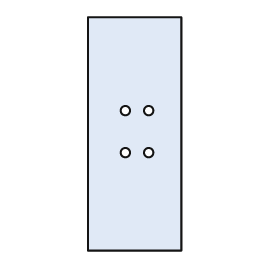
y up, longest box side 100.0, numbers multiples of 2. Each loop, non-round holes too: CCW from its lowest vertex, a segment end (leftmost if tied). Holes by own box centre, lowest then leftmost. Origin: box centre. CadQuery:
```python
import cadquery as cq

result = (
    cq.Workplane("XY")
    .moveTo(-20.0, -50.0)
    .lineTo(20.0, -50.0)
    .lineTo(20.0, 50.0)
    .lineTo(-20.0, 50.0)
    .close()
    .moveTo(-4.0, -8.0)
    .circle(2.0)
    .moveTo(6.0, -8.0)
    .circle(2.0)
    .moveTo(-4.0, 10.0)
    .circle(2.0)
    .moveTo(6.0, 10.0)
    .circle(2.0)
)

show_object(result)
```